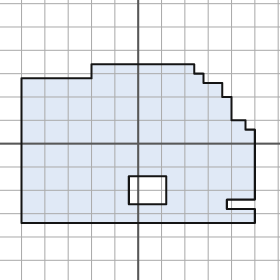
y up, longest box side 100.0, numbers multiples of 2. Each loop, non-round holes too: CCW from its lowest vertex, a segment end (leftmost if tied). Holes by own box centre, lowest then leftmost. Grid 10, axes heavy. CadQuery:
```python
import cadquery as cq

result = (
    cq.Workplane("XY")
    .moveTo(-50.0, -34.0)
    .lineTo(50.0, -34.0)
    .lineTo(50.0, -28.0)
    .lineTo(38.0, -28.0)
    .lineTo(38.0, -24.0)
    .lineTo(50.0, -24.0)
    .lineTo(50.0, 6.0)
    .lineTo(46.0, 6.0)
    .lineTo(46.0, 10.0)
    .lineTo(40.0, 10.0)
    .lineTo(40.0, 20.0)
    .lineTo(36.0, 20.0)
    .lineTo(36.0, 26.0)
    .lineTo(28.0, 26.0)
    .lineTo(28.0, 30.0)
    .lineTo(24.0, 30.0)
    .lineTo(24.0, 34.0)
    .lineTo(-20.0, 34.0)
    .lineTo(-20.0, 28.0)
    .lineTo(-50.0, 28.0)
    .close()
    .moveTo(-4.0, -26.0)
    .lineTo(12.0, -26.0)
    .lineTo(12.0, -14.0)
    .lineTo(-4.0, -14.0)
    .close()
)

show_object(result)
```